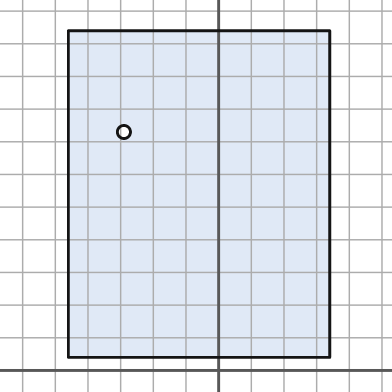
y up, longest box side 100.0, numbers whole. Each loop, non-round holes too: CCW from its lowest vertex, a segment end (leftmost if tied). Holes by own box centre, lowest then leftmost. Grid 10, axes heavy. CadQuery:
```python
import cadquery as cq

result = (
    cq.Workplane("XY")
    .moveTo(-46.0, 4.0)
    .lineTo(34.0, 4.0)
    .lineTo(34.0, 104.0)
    .lineTo(-46.0, 104.0)
    .close()
    .moveTo(-29.0, 73.0)
    .circle(2.0)
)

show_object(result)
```